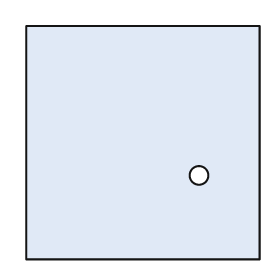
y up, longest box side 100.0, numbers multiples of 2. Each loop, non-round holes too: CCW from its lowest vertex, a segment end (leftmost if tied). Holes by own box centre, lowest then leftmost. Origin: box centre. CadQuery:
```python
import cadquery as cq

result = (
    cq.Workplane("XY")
    .moveTo(-50.0, -50.0)
    .lineTo(50.0, -50.0)
    .lineTo(50.0, 50.0)
    .lineTo(-50.0, 50.0)
    .close()
    .moveTo(24.0, -14.0)
    .circle(4.0)
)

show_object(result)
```